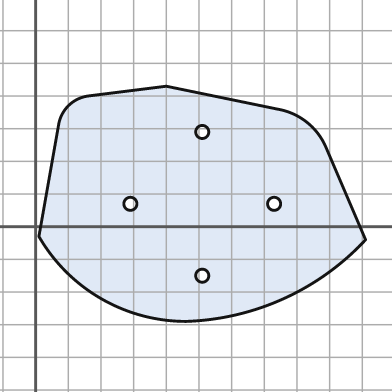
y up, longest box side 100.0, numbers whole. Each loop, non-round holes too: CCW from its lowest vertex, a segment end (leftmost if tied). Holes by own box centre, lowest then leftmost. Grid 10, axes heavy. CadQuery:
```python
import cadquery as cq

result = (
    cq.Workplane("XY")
    .moveTo(46.0, -29.0)
    .threePointArc((76.0, -22.0), (101.0, -4.0))
    .lineTo(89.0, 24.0)
    .threePointArc((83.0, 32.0), (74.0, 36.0))
    .lineTo(40.0, 43.0)
    .lineTo(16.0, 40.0)
    .threePointArc((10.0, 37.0), (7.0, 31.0))
    .lineTo(1.0, -3.0)
    .threePointArc((20.0, -22.0), (46.0, -29.0))
    .close()
    .moveTo(51.0, -15.0)
    .circle(2.0)
    .moveTo(29.0, 7.0)
    .circle(2.0)
    .moveTo(73.0, 7.0)
    .circle(2.0)
    .moveTo(51.0, 29.0)
    .circle(2.0)
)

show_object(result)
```